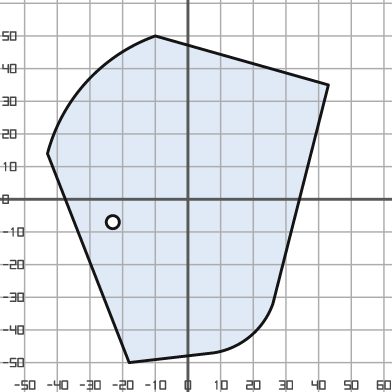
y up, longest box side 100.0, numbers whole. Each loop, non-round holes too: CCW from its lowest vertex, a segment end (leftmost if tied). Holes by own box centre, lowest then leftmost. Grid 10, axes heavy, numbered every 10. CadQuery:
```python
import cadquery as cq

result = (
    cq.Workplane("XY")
    .moveTo(-18.0, -50.0)
    .lineTo(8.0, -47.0)
    .threePointArc((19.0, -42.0), (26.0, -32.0))
    .lineTo(43.0, 35.0)
    .lineTo(-10.0, 50.0)
    .threePointArc((-31.0, 36.0), (-43.0, 14.0))
    .close()
    .moveTo(-23.0, -7.0)
    .circle(2.0)
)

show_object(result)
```